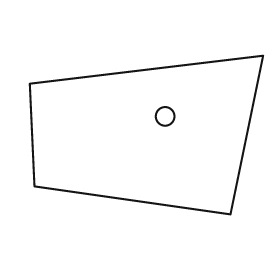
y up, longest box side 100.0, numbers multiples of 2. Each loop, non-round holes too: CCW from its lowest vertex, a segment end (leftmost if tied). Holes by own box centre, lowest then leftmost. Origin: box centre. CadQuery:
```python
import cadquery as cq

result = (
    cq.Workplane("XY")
    .moveTo(36.0, -34.0)
    .lineTo(50.0, 34.0)
    .lineTo(-50.0, 22.0)
    .lineTo(-48.0, -22.0)
    .close()
    .moveTo(8.0, 8.0)
    .circle(4.0)
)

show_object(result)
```